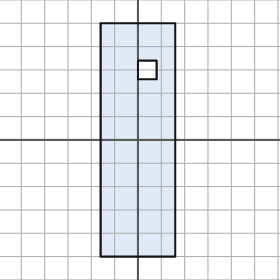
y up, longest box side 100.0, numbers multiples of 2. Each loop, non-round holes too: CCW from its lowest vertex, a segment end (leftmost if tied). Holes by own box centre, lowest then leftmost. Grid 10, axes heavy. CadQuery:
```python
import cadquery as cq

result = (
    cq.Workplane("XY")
    .moveTo(-16.0, -50.0)
    .lineTo(16.0, -50.0)
    .lineTo(16.0, 50.0)
    .lineTo(-16.0, 50.0)
    .close()
    .moveTo(0.0, 26.0)
    .lineTo(8.0, 26.0)
    .lineTo(8.0, 34.0)
    .lineTo(0.0, 34.0)
    .close()
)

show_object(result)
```